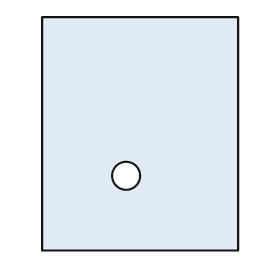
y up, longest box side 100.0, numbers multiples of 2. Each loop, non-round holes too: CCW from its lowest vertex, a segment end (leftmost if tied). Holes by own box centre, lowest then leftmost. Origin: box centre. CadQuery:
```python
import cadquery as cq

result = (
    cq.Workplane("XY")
    .moveTo(-42.0, -50.0)
    .lineTo(42.0, -50.0)
    .lineTo(42.0, 50.0)
    .lineTo(-42.0, 50.0)
    .close()
    .moveTo(-6.0, -18.0)
    .circle(6.0)
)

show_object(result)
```